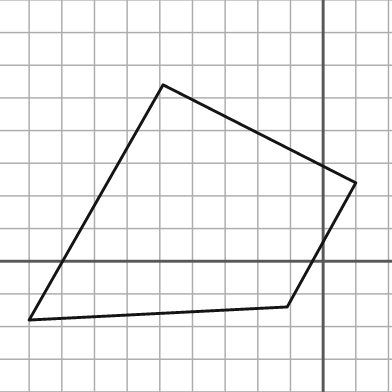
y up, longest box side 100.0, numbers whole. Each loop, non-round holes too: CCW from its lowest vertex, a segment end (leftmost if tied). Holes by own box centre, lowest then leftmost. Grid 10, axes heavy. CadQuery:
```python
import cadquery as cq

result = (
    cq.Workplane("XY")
    .moveTo(-90.0, -18.0)
    .lineTo(-11.0, -14.0)
    .lineTo(10.0, 24.0)
    .lineTo(-49.0, 54.0)
    .close()
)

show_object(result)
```